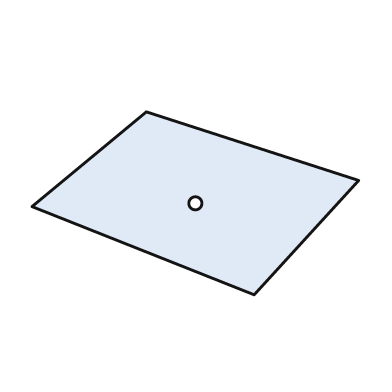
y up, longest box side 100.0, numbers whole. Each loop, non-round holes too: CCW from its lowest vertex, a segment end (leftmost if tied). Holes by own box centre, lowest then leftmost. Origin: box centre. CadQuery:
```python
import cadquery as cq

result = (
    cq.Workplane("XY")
    .moveTo(18.0, -28.0)
    .lineTo(50.0, 7.0)
    .lineTo(-15.0, 28.0)
    .lineTo(-50.0, -1.0)
    .close()
    .moveTo(0.0, 0.0)
    .circle(2.0)
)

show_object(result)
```